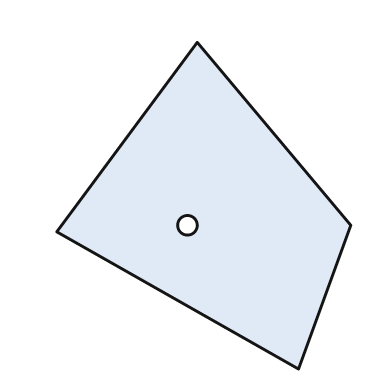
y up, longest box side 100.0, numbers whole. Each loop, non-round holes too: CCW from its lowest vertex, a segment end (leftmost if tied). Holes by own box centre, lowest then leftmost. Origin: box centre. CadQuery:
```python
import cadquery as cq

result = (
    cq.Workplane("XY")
    .moveTo(29.0, -50.0)
    .lineTo(45.0, -6.0)
    .lineTo(-2.0, 50.0)
    .lineTo(-45.0, -8.0)
    .close()
    .moveTo(-5.0, -6.0)
    .circle(3.0)
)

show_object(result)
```